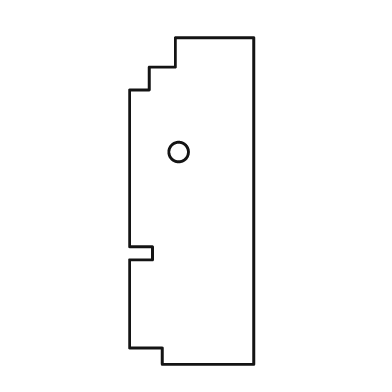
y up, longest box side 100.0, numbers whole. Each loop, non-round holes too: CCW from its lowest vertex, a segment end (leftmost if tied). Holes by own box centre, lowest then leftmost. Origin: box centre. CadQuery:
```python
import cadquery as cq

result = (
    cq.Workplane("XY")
    .moveTo(-9.0, -50.0)
    .lineTo(19.0, -50.0)
    .lineTo(19.0, 50.0)
    .lineTo(-5.0, 50.0)
    .lineTo(-5.0, 41.0)
    .lineTo(-13.0, 41.0)
    .lineTo(-13.0, 34.0)
    .lineTo(-19.0, 34.0)
    .lineTo(-19.0, -14.0)
    .lineTo(-12.0, -14.0)
    .lineTo(-12.0, -18.0)
    .lineTo(-19.0, -18.0)
    .lineTo(-19.0, -45.0)
    .lineTo(-9.0, -45.0)
    .close()
    .moveTo(-4.0, 15.0)
    .circle(3.0)
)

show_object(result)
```